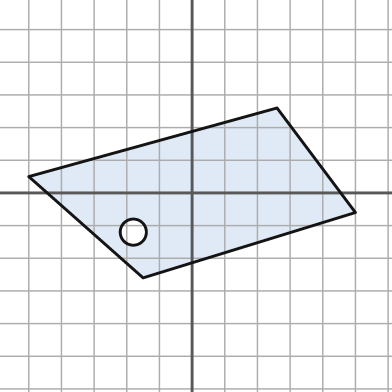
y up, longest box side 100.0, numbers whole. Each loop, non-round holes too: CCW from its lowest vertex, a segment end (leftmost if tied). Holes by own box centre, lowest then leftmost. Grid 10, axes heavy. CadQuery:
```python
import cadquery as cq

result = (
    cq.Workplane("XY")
    .moveTo(-15.0, -26.0)
    .lineTo(50.0, -6.0)
    .lineTo(26.0, 26.0)
    .lineTo(-50.0, 5.0)
    .close()
    .moveTo(-18.0, -12.0)
    .circle(4.0)
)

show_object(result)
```